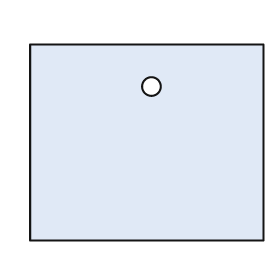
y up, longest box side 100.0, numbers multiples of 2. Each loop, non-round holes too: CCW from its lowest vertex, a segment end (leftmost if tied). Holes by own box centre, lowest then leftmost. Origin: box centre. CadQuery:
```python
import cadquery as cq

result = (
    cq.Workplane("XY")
    .moveTo(-50.0, -42.0)
    .lineTo(50.0, -42.0)
    .lineTo(50.0, 42.0)
    .lineTo(-50.0, 42.0)
    .close()
    .moveTo(2.0, 24.0)
    .circle(4.0)
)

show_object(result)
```